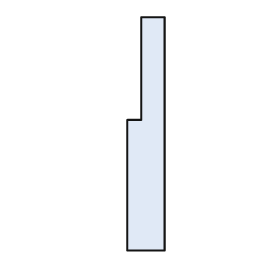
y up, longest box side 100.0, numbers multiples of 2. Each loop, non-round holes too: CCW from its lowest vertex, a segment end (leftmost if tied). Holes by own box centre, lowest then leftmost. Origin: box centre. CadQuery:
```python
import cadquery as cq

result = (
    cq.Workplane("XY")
    .moveTo(-8.0, -50.0)
    .lineTo(8.0, -50.0)
    .lineTo(8.0, 50.0)
    .lineTo(-2.0, 50.0)
    .lineTo(-2.0, 6.0)
    .lineTo(-8.0, 6.0)
    .close()
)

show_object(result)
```